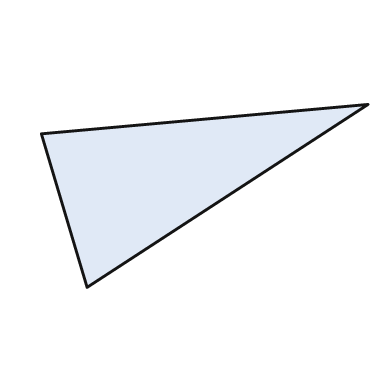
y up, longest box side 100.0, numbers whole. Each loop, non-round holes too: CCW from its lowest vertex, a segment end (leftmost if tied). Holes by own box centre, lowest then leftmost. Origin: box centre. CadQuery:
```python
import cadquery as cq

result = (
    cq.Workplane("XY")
    .moveTo(-36.0, -28.0)
    .lineTo(50.0, 28.0)
    .lineTo(-50.0, 19.0)
    .close()
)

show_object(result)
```